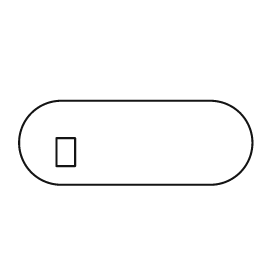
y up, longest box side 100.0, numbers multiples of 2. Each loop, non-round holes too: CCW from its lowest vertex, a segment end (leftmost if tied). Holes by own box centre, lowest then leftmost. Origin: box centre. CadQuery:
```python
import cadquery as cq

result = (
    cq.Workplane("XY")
    .moveTo(-32.0, -18.0)
    .lineTo(32.0, -18.0)
    .threePointArc((50.0, 0.0), (32.0, 18.0))
    .lineTo(-32.0, 18.0)
    .threePointArc((-50.0, 0.0), (-32.0, -18.0))
    .close()
    .moveTo(-34.0, -10.0)
    .lineTo(-26.0, -10.0)
    .lineTo(-26.0, 2.0)
    .lineTo(-34.0, 2.0)
    .close()
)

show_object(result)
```